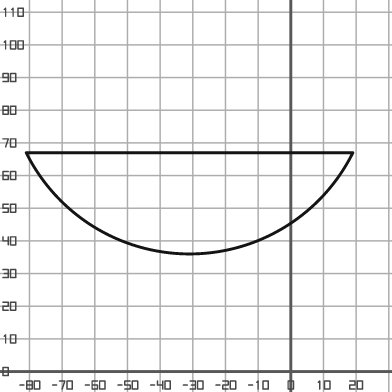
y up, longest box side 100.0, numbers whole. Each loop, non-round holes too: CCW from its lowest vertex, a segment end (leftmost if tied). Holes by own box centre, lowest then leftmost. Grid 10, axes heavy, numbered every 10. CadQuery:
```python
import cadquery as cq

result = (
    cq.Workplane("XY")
    .moveTo(-81.0, 67.0)
    .threePointArc((-31.0, 36.0), (19.0, 67.0))
    .close()
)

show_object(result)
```